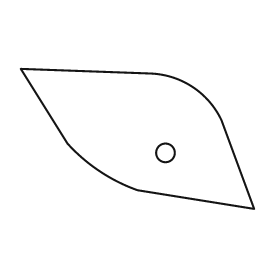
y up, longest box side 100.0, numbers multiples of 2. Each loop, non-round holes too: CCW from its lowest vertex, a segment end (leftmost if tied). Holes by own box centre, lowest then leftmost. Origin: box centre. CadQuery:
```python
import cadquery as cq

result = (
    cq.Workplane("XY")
    .moveTo(50.0, -30.0)
    .lineTo(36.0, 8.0)
    .threePointArc((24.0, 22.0), (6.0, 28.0))
    .lineTo(-50.0, 30.0)
    .lineTo(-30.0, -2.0)
    .threePointArc((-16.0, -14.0), (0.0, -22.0))
    .close()
    .moveTo(12.0, -6.0)
    .circle(4.0)
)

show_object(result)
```